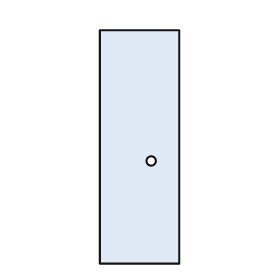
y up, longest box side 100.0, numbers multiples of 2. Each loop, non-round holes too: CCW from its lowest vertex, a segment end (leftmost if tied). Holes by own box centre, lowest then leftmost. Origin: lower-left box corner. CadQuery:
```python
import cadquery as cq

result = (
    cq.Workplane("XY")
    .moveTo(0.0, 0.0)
    .lineTo(34.0, 0.0)
    .lineTo(34.0, 100.0)
    .lineTo(0.0, 100.0)
    .close()
    .moveTo(22.0, 44.0)
    .circle(2.0)
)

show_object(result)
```